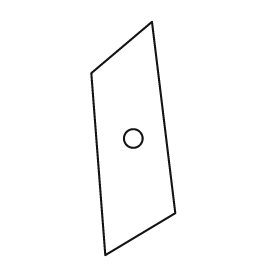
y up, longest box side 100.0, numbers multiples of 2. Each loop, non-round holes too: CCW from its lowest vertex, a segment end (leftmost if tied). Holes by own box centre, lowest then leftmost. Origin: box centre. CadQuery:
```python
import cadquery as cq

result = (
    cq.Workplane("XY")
    .moveTo(-12.0, -50.0)
    .lineTo(18.0, -32.0)
    .lineTo(8.0, 50.0)
    .lineTo(-18.0, 28.0)
    .close()
    .moveTo(0.0, 0.0)
    .circle(4.0)
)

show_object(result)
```